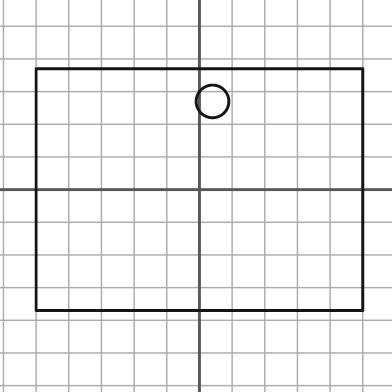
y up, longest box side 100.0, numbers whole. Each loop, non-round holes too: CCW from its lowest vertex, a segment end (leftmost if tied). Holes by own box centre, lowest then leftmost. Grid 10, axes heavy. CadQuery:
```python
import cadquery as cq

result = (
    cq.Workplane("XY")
    .moveTo(-50.0, -37.0)
    .lineTo(50.0, -37.0)
    .lineTo(50.0, 37.0)
    .lineTo(-50.0, 37.0)
    .close()
    .moveTo(4.0, 27.0)
    .circle(5.0)
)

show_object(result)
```